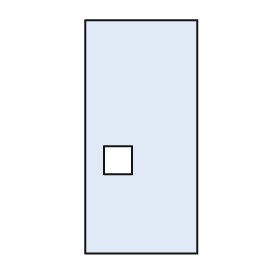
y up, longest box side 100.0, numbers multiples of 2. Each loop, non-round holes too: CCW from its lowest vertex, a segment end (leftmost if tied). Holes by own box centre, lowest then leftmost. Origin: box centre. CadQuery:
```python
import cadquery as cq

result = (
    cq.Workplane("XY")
    .moveTo(-24.0, -50.0)
    .lineTo(24.0, -50.0)
    .lineTo(24.0, 50.0)
    .lineTo(-24.0, 50.0)
    .close()
    .moveTo(-16.0, -16.0)
    .lineTo(-4.0, -16.0)
    .lineTo(-4.0, -4.0)
    .lineTo(-16.0, -4.0)
    .close()
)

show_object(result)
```